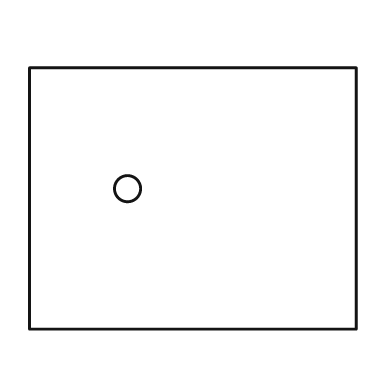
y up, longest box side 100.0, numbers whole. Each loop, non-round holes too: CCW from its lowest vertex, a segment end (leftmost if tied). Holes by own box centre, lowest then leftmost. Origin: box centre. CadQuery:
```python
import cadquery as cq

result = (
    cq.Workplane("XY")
    .moveTo(-50.0, -40.0)
    .lineTo(50.0, -40.0)
    .lineTo(50.0, 40.0)
    .lineTo(-50.0, 40.0)
    .close()
    .moveTo(-20.0, 3.0)
    .circle(4.0)
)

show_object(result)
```